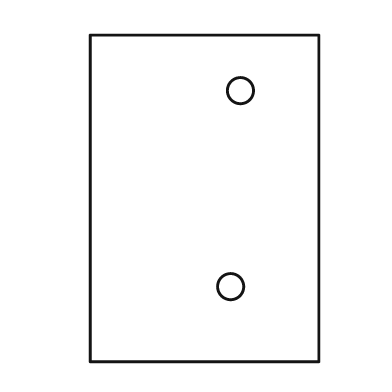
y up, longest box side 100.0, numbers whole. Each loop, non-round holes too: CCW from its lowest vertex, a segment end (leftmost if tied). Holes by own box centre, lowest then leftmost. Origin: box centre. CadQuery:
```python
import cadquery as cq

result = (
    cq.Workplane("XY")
    .moveTo(-35.0, -50.0)
    .lineTo(35.0, -50.0)
    .lineTo(35.0, 50.0)
    .lineTo(-35.0, 50.0)
    .close()
    .moveTo(8.0, -27.0)
    .circle(4.0)
    .moveTo(11.0, 33.0)
    .circle(4.0)
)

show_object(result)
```